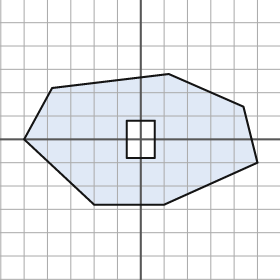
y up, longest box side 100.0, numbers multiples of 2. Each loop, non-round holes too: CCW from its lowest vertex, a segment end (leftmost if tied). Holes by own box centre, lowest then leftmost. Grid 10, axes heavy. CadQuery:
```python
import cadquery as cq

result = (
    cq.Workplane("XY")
    .moveTo(-20.0, -28.0)
    .lineTo(10.0, -28.0)
    .lineTo(50.0, -10.0)
    .lineTo(44.0, 14.0)
    .lineTo(12.0, 28.0)
    .lineTo(-38.0, 22.0)
    .lineTo(-50.0, 0.0)
    .close()
    .moveTo(-6.0, -8.0)
    .lineTo(6.0, -8.0)
    .lineTo(6.0, 8.0)
    .lineTo(-6.0, 8.0)
    .close()
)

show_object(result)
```